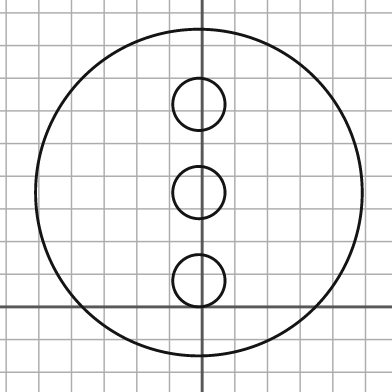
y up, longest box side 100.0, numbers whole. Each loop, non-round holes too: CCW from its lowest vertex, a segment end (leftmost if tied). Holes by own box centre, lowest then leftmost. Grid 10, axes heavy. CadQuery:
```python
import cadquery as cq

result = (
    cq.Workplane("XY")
    .moveTo(-1.0, 35.0)
    .circle(50.0)
    .moveTo(-1.0, 8.0)
    .circle(8.0)
    .moveTo(-1.0, 35.0)
    .circle(8.0)
    .moveTo(-1.0, 62.0)
    .circle(8.0)
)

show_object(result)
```